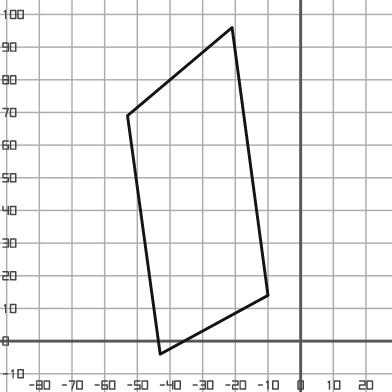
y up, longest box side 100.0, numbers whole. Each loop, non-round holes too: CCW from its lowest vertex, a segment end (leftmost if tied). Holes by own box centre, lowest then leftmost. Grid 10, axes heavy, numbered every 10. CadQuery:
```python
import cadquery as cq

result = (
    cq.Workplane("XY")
    .moveTo(-43.0, -4.0)
    .lineTo(-10.0, 14.0)
    .lineTo(-21.0, 96.0)
    .lineTo(-53.0, 69.0)
    .close()
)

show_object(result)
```